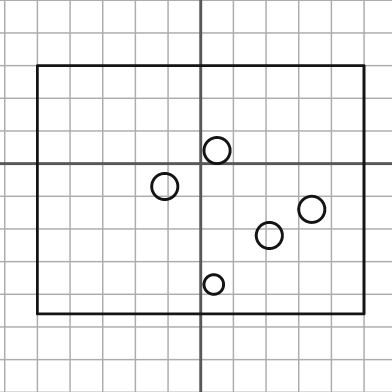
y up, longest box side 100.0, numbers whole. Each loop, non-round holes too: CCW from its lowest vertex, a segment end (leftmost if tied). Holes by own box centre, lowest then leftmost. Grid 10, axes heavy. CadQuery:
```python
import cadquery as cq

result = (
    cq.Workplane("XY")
    .moveTo(-50.0, -46.0)
    .lineTo(50.0, -46.0)
    .lineTo(50.0, 30.0)
    .lineTo(-50.0, 30.0)
    .close()
    .moveTo(4.0, -37.0)
    .circle(3.0)
    .moveTo(21.0, -22.0)
    .circle(4.0)
    .moveTo(34.0, -14.0)
    .circle(4.0)
    .moveTo(-11.0, -7.0)
    .circle(4.0)
    .moveTo(5.0, 4.0)
    .circle(4.0)
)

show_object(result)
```